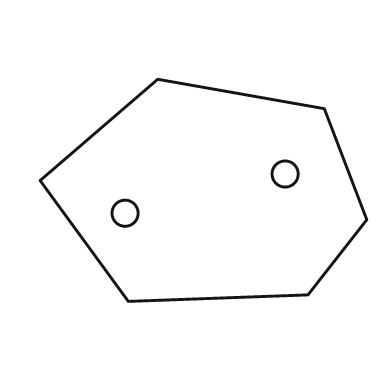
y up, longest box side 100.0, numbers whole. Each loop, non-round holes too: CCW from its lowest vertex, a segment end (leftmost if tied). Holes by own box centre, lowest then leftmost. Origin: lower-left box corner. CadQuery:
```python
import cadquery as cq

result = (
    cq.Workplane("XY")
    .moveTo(27.0, 0.0)
    .lineTo(82.0, 2.0)
    .lineTo(100.0, 25.0)
    .lineTo(87.0, 59.0)
    .lineTo(36.0, 68.0)
    .lineTo(0.0, 37.0)
    .close()
    .moveTo(26.0, 27.0)
    .circle(4.0)
    .moveTo(75.0, 39.0)
    .circle(4.0)
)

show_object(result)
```